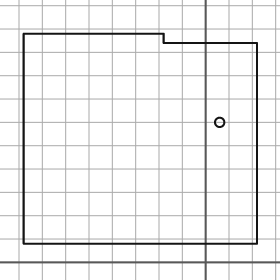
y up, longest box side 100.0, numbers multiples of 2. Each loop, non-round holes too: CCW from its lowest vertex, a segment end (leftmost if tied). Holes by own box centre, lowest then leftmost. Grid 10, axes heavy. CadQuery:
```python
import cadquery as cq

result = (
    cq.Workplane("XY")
    .moveTo(-78.0, 8.0)
    .lineTo(22.0, 8.0)
    .lineTo(22.0, 94.0)
    .lineTo(-18.0, 94.0)
    .lineTo(-18.0, 98.0)
    .lineTo(-78.0, 98.0)
    .close()
    .moveTo(6.0, 60.0)
    .circle(2.0)
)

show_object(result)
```